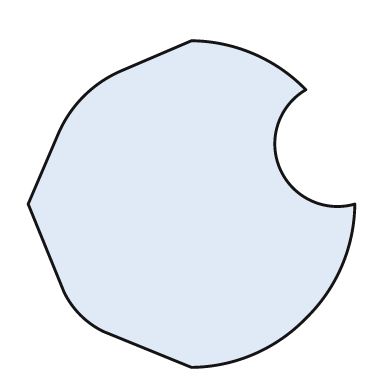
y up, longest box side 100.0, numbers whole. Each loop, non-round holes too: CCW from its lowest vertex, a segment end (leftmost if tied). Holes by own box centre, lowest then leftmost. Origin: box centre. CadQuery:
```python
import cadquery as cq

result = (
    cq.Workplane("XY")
    .moveTo(0.0, -50.0)
    .threePointArc((19.0, -46.0), (35.0, -35.0))
    .threePointArc((46.0, -19.0), (50.0, 0.0))
    .threePointArc((27.0, 11.0), (35.0, 35.0))
    .threePointArc((19.0, 46.0), (0.0, 50.0))
    .lineTo(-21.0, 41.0)
    .threePointArc((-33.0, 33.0), (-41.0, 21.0))
    .lineTo(-50.0, 0.0)
    .lineTo(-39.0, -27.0)
    .threePointArc((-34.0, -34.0), (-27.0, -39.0))
    .close()
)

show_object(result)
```